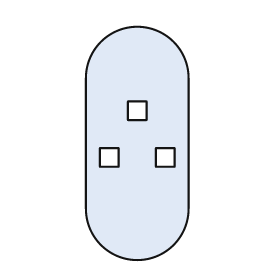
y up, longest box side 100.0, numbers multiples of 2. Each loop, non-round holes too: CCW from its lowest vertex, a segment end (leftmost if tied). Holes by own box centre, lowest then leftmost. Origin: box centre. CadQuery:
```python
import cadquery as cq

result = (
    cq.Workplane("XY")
    .moveTo(-22.0, -28.0)
    .threePointArc((0.0, -50.0), (22.0, -28.0))
    .lineTo(22.0, 28.0)
    .threePointArc((0.0, 50.0), (-22.0, 28.0))
    .close()
    .moveTo(-16.0, -10.0)
    .lineTo(-8.0, -10.0)
    .lineTo(-8.0, -2.0)
    .lineTo(-16.0, -2.0)
    .close()
    .moveTo(8.0, -10.0)
    .lineTo(16.0, -10.0)
    .lineTo(16.0, -2.0)
    .lineTo(8.0, -2.0)
    .close()
    .moveTo(-4.0, 10.0)
    .lineTo(4.0, 10.0)
    .lineTo(4.0, 18.0)
    .lineTo(-4.0, 18.0)
    .close()
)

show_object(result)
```